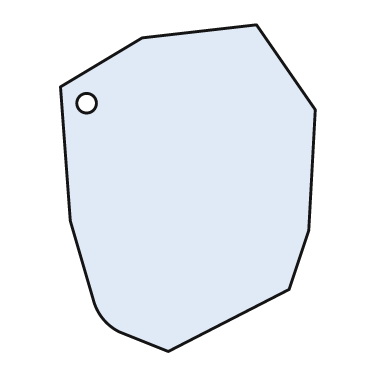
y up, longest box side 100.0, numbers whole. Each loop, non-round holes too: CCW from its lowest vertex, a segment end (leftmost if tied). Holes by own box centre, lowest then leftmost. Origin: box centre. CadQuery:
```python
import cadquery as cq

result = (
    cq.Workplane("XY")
    .moveTo(-6.0, -50.0)
    .lineTo(31.0, -31.0)
    .lineTo(37.0, -13.0)
    .lineTo(39.0, 24.0)
    .lineTo(21.0, 50.0)
    .lineTo(-14.0, 46.0)
    .lineTo(-39.0, 31.0)
    .lineTo(-36.0, -10.0)
    .lineTo(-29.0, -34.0)
    .threePointArc((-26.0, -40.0), (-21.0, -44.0))
    .close()
    .moveTo(-31.0, 26.0)
    .circle(3.0)
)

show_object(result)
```